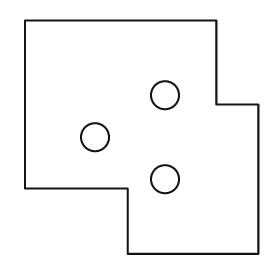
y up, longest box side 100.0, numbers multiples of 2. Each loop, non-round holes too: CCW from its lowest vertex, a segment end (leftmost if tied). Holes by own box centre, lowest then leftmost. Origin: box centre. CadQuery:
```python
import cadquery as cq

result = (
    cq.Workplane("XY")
    .moveTo(-6.0, -50.0)
    .lineTo(50.0, -50.0)
    .lineTo(50.0, 14.0)
    .lineTo(32.0, 14.0)
    .lineTo(32.0, 50.0)
    .lineTo(-50.0, 50.0)
    .lineTo(-50.0, -22.0)
    .lineTo(-6.0, -22.0)
    .close()
    .moveTo(10.0, -18.0)
    .circle(6.0)
    .moveTo(-20.0, 0.0)
    .circle(6.0)
    .moveTo(10.0, 18.0)
    .circle(6.0)
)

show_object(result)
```